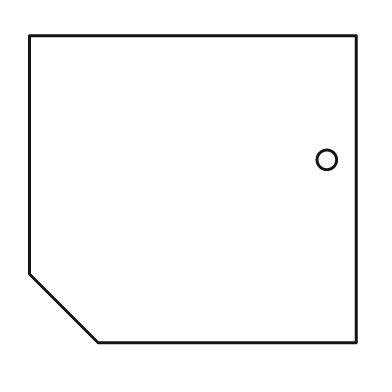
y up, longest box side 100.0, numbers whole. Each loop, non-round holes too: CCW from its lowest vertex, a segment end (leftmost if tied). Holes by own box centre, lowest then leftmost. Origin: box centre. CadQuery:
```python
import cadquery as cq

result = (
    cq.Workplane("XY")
    .moveTo(-29.0, -47.0)
    .lineTo(50.0, -47.0)
    .lineTo(50.0, 47.0)
    .lineTo(-50.0, 47.0)
    .lineTo(-50.0, -26.0)
    .close()
    .moveTo(41.0, 9.0)
    .circle(3.0)
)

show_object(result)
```